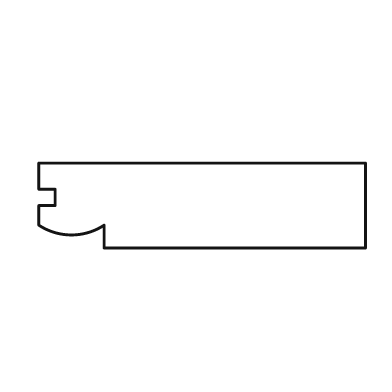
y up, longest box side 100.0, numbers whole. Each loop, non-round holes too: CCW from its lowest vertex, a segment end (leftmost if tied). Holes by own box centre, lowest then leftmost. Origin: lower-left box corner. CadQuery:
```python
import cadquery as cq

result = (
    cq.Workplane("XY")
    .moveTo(20.0, 0.0)
    .lineTo(100.0, 0.0)
    .lineTo(100.0, 26.0)
    .lineTo(0.0, 26.0)
    .lineTo(0.0, 18.0)
    .lineTo(5.0, 18.0)
    .lineTo(5.0, 13.0)
    .lineTo(0.0, 13.0)
    .lineTo(0.0, 7.0)
    .threePointArc((10.0, 4.0), (20.0, 7.0))
    .close()
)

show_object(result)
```